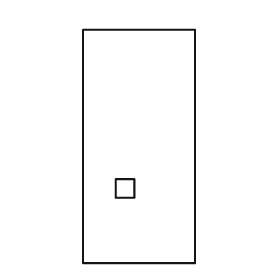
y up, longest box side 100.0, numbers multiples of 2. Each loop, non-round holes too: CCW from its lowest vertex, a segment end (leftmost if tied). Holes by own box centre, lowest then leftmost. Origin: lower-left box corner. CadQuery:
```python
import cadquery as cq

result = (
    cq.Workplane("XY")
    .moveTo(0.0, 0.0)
    .lineTo(48.0, 0.0)
    .lineTo(48.0, 100.0)
    .lineTo(0.0, 100.0)
    .close()
    .moveTo(14.0, 28.0)
    .lineTo(22.0, 28.0)
    .lineTo(22.0, 36.0)
    .lineTo(14.0, 36.0)
    .close()
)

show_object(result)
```